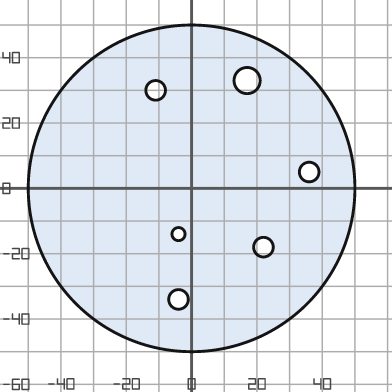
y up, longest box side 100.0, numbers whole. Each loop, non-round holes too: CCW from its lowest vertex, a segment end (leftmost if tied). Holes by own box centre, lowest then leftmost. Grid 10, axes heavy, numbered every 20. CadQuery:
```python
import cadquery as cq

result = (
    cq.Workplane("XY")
    .moveTo(0.0, 0.0)
    .circle(50.0)
    .moveTo(-4.0, -34.0)
    .circle(3.0)
    .moveTo(22.0, -18.0)
    .circle(3.0)
    .moveTo(-4.0, -14.0)
    .circle(2.0)
    .moveTo(36.0, 5.0)
    .circle(3.0)
    .moveTo(-11.0, 30.0)
    .circle(3.0)
    .moveTo(17.0, 33.0)
    .circle(4.0)
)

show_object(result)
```